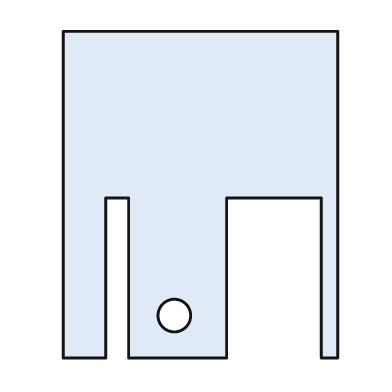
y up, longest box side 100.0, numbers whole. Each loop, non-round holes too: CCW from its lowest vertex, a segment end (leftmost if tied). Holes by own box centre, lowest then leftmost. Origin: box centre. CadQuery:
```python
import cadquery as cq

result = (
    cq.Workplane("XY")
    .moveTo(-42.0, -50.0)
    .lineTo(-29.0, -50.0)
    .lineTo(-29.0, -1.0)
    .lineTo(-22.0, -1.0)
    .lineTo(-22.0, -50.0)
    .lineTo(8.0, -50.0)
    .lineTo(8.0, -1.0)
    .lineTo(37.0, -1.0)
    .lineTo(37.0, -50.0)
    .lineTo(42.0, -50.0)
    .lineTo(42.0, 50.0)
    .lineTo(-42.0, 50.0)
    .close()
    .moveTo(-8.0, -37.0)
    .circle(5.0)
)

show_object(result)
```